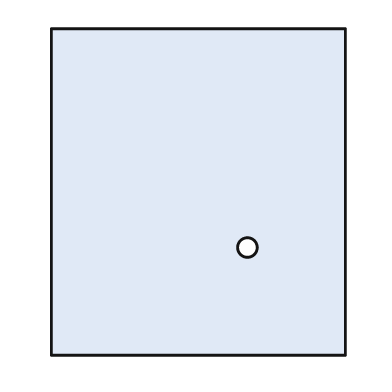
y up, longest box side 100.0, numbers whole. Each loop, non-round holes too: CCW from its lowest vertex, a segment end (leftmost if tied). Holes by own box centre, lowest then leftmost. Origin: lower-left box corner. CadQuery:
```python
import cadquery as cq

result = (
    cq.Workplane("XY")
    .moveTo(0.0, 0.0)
    .lineTo(90.0, 0.0)
    .lineTo(90.0, 100.0)
    .lineTo(0.0, 100.0)
    .close()
    .moveTo(60.0, 33.0)
    .circle(3.0)
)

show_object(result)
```